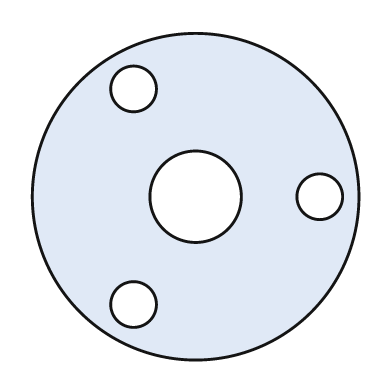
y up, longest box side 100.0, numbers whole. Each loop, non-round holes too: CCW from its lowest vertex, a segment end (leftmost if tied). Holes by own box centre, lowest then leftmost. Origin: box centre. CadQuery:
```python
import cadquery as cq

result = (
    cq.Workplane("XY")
    .moveTo(0.0, 0.0)
    .circle(50.0)
    .moveTo(-19.0, -33.0)
    .circle(7.0)
    .moveTo(0.0, 0.0)
    .circle(14.0)
    .moveTo(38.0, 0.0)
    .circle(7.0)
    .moveTo(-19.0, 33.0)
    .circle(7.0)
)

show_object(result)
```